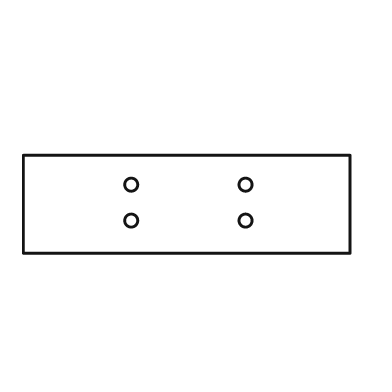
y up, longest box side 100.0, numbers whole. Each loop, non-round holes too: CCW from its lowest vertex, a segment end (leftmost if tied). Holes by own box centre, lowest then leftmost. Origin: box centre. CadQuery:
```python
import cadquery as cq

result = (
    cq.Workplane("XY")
    .moveTo(-50.0, -15.0)
    .lineTo(50.0, -15.0)
    .lineTo(50.0, 15.0)
    .lineTo(-50.0, 15.0)
    .close()
    .moveTo(-17.0, -5.0)
    .circle(2.0)
    .moveTo(18.0, -5.0)
    .circle(2.0)
    .moveTo(-17.0, 6.0)
    .circle(2.0)
    .moveTo(18.0, 6.0)
    .circle(2.0)
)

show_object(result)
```